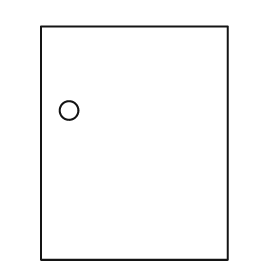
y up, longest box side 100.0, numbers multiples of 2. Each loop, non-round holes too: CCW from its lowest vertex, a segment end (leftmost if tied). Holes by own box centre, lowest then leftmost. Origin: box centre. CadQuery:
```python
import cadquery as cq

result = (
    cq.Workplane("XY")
    .moveTo(-40.0, -50.0)
    .lineTo(40.0, -50.0)
    .lineTo(40.0, 50.0)
    .lineTo(-40.0, 50.0)
    .close()
    .moveTo(-28.0, 14.0)
    .circle(4.0)
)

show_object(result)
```